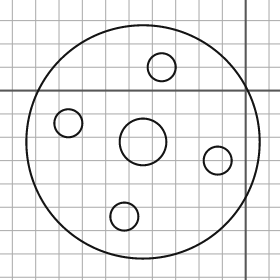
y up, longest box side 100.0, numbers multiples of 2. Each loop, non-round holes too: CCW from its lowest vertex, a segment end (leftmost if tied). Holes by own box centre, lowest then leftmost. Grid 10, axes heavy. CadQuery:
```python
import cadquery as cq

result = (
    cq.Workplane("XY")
    .moveTo(-44.0, -22.0)
    .circle(50.0)
    .moveTo(-52.0, -54.0)
    .circle(6.0)
    .moveTo(-12.0, -30.0)
    .circle(6.0)
    .moveTo(-44.0, -22.0)
    .circle(10.0)
    .moveTo(-76.0, -14.0)
    .circle(6.0)
    .moveTo(-36.0, 10.0)
    .circle(6.0)
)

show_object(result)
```